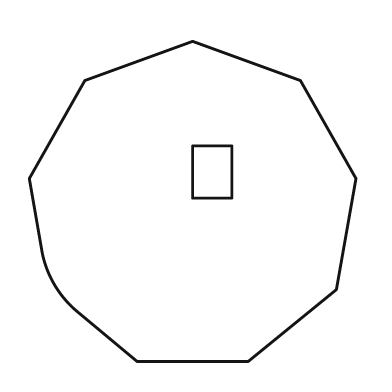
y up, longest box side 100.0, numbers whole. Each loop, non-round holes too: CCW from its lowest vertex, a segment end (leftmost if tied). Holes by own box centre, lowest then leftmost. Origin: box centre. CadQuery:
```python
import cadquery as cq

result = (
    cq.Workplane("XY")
    .moveTo(-17.0, -49.0)
    .lineTo(17.0, -49.0)
    .lineTo(44.0, -27.0)
    .lineTo(50.0, 7.0)
    .lineTo(33.0, 37.0)
    .lineTo(0.0, 49.0)
    .lineTo(-33.0, 37.0)
    .lineTo(-50.0, 7.0)
    .lineTo(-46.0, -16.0)
    .threePointArc((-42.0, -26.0), (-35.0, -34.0))
    .close()
    .moveTo(0.0, 1.0)
    .lineTo(12.0, 1.0)
    .lineTo(12.0, 17.0)
    .lineTo(0.0, 17.0)
    .close()
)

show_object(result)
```